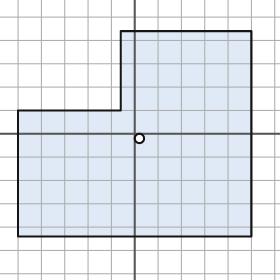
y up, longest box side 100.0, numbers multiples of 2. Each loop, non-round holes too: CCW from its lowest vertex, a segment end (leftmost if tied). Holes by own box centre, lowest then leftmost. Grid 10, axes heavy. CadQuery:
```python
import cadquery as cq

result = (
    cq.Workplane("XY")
    .moveTo(-50.0, -44.0)
    .lineTo(50.0, -44.0)
    .lineTo(50.0, 44.0)
    .lineTo(-6.0, 44.0)
    .lineTo(-6.0, 10.0)
    .lineTo(-50.0, 10.0)
    .close()
    .moveTo(2.0, -2.0)
    .circle(2.0)
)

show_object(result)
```